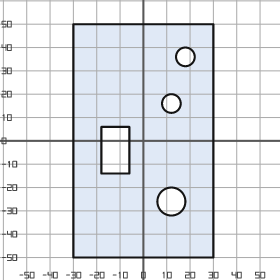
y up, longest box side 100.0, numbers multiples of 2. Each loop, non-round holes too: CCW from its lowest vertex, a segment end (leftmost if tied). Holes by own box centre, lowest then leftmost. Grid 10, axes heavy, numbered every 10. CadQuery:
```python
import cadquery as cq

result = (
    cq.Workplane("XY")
    .moveTo(-30.0, -50.0)
    .lineTo(30.0, -50.0)
    .lineTo(30.0, 50.0)
    .lineTo(-30.0, 50.0)
    .close()
    .moveTo(12.0, -26.0)
    .circle(6.0)
    .moveTo(-18.0, -14.0)
    .lineTo(-6.0, -14.0)
    .lineTo(-6.0, 6.0)
    .lineTo(-18.0, 6.0)
    .close()
    .moveTo(12.0, 16.0)
    .circle(4.0)
    .moveTo(18.0, 36.0)
    .circle(4.0)
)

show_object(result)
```